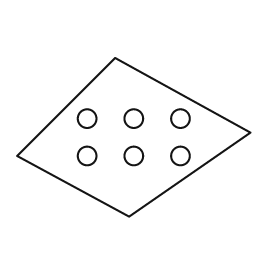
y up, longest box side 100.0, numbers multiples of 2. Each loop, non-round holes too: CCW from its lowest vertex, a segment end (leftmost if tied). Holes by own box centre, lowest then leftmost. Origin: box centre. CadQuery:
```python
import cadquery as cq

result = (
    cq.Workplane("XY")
    .moveTo(-2.0, -34.0)
    .lineTo(50.0, 2.0)
    .lineTo(-8.0, 34.0)
    .lineTo(-50.0, -8.0)
    .close()
    .moveTo(-20.0, -8.0)
    .circle(4.0)
    .moveTo(0.0, -8.0)
    .circle(4.0)
    .moveTo(20.0, -8.0)
    .circle(4.0)
    .moveTo(-20.0, 8.0)
    .circle(4.0)
    .moveTo(0.0, 8.0)
    .circle(4.0)
    .moveTo(20.0, 8.0)
    .circle(4.0)
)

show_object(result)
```